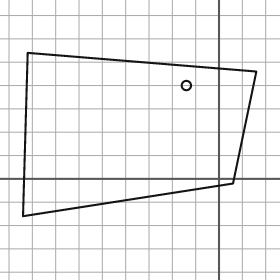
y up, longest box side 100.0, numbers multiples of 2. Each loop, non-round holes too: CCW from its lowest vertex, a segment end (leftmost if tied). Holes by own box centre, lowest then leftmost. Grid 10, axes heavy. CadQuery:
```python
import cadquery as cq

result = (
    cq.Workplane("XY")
    .moveTo(-84.0, -16.0)
    .lineTo(6.0, -2.0)
    .lineTo(16.0, 46.0)
    .lineTo(-82.0, 54.0)
    .close()
    .moveTo(-14.0, 40.0)
    .circle(2.0)
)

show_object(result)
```